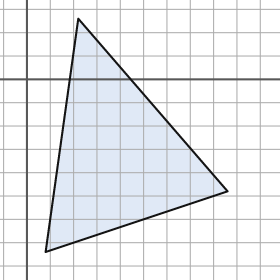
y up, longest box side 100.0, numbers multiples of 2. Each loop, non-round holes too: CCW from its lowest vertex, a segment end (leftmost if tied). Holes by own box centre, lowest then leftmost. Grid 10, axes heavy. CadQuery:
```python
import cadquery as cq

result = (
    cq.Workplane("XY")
    .moveTo(8.0, -74.0)
    .lineTo(86.0, -48.0)
    .lineTo(22.0, 26.0)
    .close()
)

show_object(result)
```